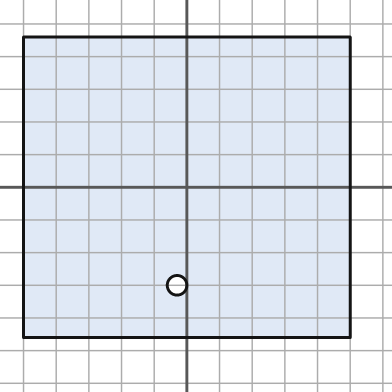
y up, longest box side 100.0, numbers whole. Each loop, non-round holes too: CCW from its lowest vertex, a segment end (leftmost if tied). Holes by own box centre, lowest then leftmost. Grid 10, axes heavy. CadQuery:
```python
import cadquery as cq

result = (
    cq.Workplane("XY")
    .moveTo(-50.0, -46.0)
    .lineTo(50.0, -46.0)
    .lineTo(50.0, 46.0)
    .lineTo(-50.0, 46.0)
    .close()
    .moveTo(-3.0, -30.0)
    .circle(3.0)
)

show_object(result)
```